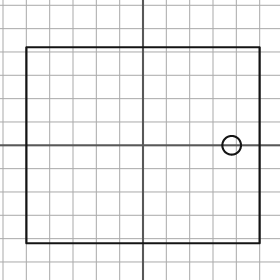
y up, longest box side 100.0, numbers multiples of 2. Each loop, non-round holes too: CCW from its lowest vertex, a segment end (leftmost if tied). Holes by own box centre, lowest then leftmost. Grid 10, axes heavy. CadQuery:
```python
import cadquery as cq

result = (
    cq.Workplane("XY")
    .moveTo(-50.0, -42.0)
    .lineTo(50.0, -42.0)
    .lineTo(50.0, 42.0)
    .lineTo(-50.0, 42.0)
    .close()
    .moveTo(38.0, 0.0)
    .circle(4.0)
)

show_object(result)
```